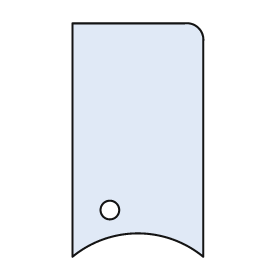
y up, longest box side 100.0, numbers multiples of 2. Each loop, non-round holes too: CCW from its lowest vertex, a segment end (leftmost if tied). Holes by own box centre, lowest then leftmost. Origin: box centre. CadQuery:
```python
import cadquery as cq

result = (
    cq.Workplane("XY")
    .moveTo(-28.0, -50.0)
    .threePointArc((0.0, -40.0), (28.0, -50.0))
    .lineTo(28.0, 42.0)
    .threePointArc((26.0, 48.0), (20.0, 50.0))
    .lineTo(-28.0, 50.0)
    .close()
    .moveTo(-12.0, -30.0)
    .circle(4.0)
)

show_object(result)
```